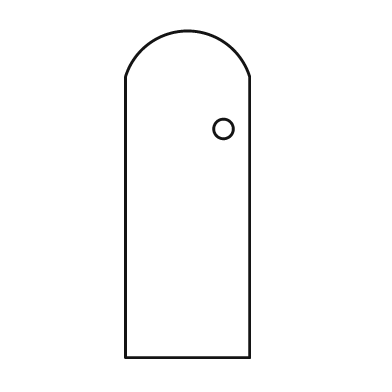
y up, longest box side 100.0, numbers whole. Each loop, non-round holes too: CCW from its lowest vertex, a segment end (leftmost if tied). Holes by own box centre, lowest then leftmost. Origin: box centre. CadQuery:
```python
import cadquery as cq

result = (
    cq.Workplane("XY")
    .moveTo(-19.0, -50.0)
    .lineTo(19.0, -50.0)
    .lineTo(19.0, 36.0)
    .threePointArc((0.0, 50.0), (-19.0, 36.0))
    .close()
    .moveTo(11.0, 20.0)
    .circle(3.0)
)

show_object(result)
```